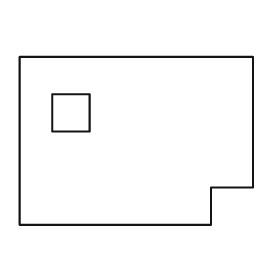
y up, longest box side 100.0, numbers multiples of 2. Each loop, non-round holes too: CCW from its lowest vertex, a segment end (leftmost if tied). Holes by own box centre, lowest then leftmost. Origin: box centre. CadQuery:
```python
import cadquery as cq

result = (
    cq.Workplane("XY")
    .moveTo(-50.0, -36.0)
    .lineTo(32.0, -36.0)
    .lineTo(32.0, -20.0)
    .lineTo(50.0, -20.0)
    .lineTo(50.0, 36.0)
    .lineTo(-50.0, 36.0)
    .close()
    .moveTo(-36.0, 4.0)
    .lineTo(-20.0, 4.0)
    .lineTo(-20.0, 20.0)
    .lineTo(-36.0, 20.0)
    .close()
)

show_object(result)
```